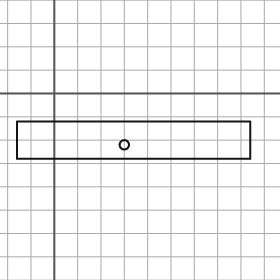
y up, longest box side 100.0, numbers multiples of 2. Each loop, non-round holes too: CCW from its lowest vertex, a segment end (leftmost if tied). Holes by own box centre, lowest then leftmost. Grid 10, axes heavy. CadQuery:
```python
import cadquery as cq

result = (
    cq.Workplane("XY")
    .moveTo(-16.0, -28.0)
    .lineTo(84.0, -28.0)
    .lineTo(84.0, -12.0)
    .lineTo(-16.0, -12.0)
    .close()
    .moveTo(30.0, -22.0)
    .circle(2.0)
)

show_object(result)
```